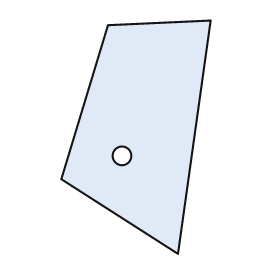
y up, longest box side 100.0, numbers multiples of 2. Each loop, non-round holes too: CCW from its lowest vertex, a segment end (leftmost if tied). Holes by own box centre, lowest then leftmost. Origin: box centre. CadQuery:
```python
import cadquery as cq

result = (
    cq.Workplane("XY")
    .moveTo(18.0, -50.0)
    .lineTo(32.0, 50.0)
    .lineTo(-12.0, 48.0)
    .lineTo(-32.0, -18.0)
    .close()
    .moveTo(-6.0, -8.0)
    .circle(4.0)
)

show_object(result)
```